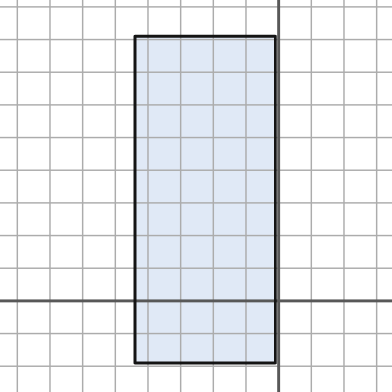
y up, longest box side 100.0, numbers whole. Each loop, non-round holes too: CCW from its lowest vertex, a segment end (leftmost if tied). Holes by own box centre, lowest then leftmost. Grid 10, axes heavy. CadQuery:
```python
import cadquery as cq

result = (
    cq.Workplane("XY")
    .moveTo(-44.0, -19.0)
    .lineTo(-1.0, -19.0)
    .lineTo(-1.0, 81.0)
    .lineTo(-44.0, 81.0)
    .close()
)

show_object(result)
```